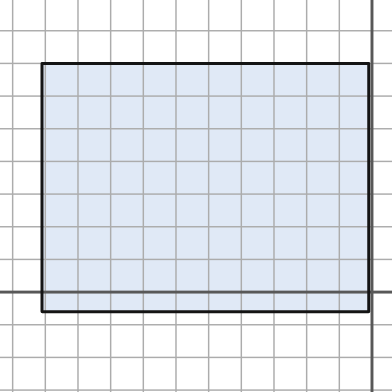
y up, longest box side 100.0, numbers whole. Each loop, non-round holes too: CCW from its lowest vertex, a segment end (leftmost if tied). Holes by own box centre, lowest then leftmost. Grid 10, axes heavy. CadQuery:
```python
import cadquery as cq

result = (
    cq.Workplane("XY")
    .moveTo(-101.0, -6.0)
    .lineTo(-1.0, -6.0)
    .lineTo(-1.0, 70.0)
    .lineTo(-101.0, 70.0)
    .close()
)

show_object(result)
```